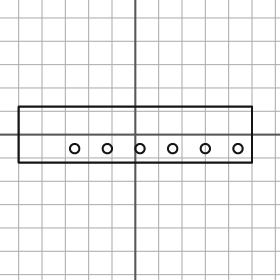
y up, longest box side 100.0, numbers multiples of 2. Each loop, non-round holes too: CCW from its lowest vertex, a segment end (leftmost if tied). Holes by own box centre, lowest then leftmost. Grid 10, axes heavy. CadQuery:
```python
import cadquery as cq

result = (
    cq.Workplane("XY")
    .moveTo(-50.0, -12.0)
    .lineTo(50.0, -12.0)
    .lineTo(50.0, 12.0)
    .lineTo(-50.0, 12.0)
    .close()
    .moveTo(-26.0, -6.0)
    .circle(2.0)
    .moveTo(-12.0, -6.0)
    .circle(2.0)
    .moveTo(2.0, -6.0)
    .circle(2.0)
    .moveTo(16.0, -6.0)
    .circle(2.0)
    .moveTo(30.0, -6.0)
    .circle(2.0)
    .moveTo(44.0, -6.0)
    .circle(2.0)
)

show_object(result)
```